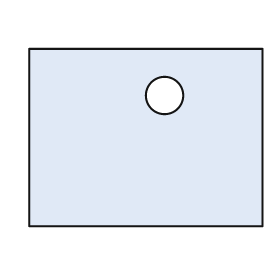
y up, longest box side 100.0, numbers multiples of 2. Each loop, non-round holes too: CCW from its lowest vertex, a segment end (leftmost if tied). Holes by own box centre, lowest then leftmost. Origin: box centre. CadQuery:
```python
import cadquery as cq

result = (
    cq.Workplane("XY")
    .moveTo(-50.0, -38.0)
    .lineTo(50.0, -38.0)
    .lineTo(50.0, 38.0)
    .lineTo(-50.0, 38.0)
    .close()
    .moveTo(8.0, 18.0)
    .circle(8.0)
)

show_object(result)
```